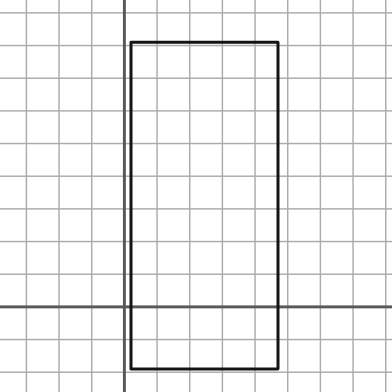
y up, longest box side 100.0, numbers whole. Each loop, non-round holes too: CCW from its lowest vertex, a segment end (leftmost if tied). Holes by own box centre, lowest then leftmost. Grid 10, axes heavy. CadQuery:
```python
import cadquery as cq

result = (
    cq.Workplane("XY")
    .moveTo(2.0, -19.0)
    .lineTo(47.0, -19.0)
    .lineTo(47.0, 81.0)
    .lineTo(2.0, 81.0)
    .close()
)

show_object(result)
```